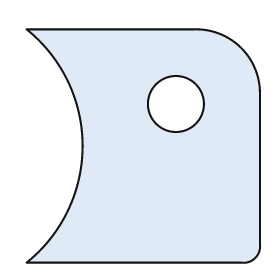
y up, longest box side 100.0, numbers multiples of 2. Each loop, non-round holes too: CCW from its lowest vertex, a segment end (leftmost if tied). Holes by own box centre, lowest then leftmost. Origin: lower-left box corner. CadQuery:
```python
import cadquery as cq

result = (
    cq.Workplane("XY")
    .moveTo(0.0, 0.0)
    .lineTo(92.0, 0.0)
    .threePointArc((98.0, 2.0), (100.0, 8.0))
    .lineTo(100.0, 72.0)
    .threePointArc((92.0, 92.0), (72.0, 100.0))
    .lineTo(0.0, 100.0)
    .threePointArc((24.0, 50.0), (0.0, 0.0))
    .close()
    .moveTo(64.0, 68.0)
    .circle(12.0)
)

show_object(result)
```